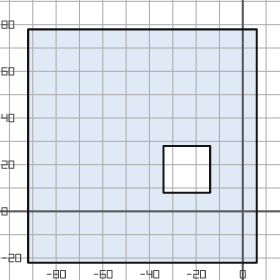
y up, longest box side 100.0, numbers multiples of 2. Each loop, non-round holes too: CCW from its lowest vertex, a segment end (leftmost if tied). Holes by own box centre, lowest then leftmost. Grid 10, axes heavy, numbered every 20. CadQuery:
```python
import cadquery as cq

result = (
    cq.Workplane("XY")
    .moveTo(-92.0, -22.0)
    .lineTo(6.0, -22.0)
    .lineTo(6.0, 78.0)
    .lineTo(-92.0, 78.0)
    .close()
    .moveTo(-34.0, 8.0)
    .lineTo(-14.0, 8.0)
    .lineTo(-14.0, 28.0)
    .lineTo(-34.0, 28.0)
    .close()
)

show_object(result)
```